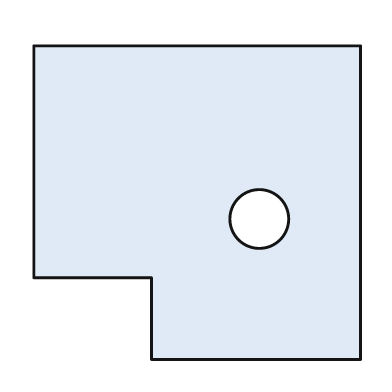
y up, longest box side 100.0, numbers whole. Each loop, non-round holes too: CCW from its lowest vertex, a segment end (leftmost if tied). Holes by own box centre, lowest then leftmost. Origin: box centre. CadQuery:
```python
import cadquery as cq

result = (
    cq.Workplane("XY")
    .moveTo(-14.0, -48.0)
    .lineTo(50.0, -48.0)
    .lineTo(50.0, 48.0)
    .lineTo(-50.0, 48.0)
    .lineTo(-50.0, -23.0)
    .lineTo(-14.0, -23.0)
    .close()
    .moveTo(19.0, -5.0)
    .circle(9.0)
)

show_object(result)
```